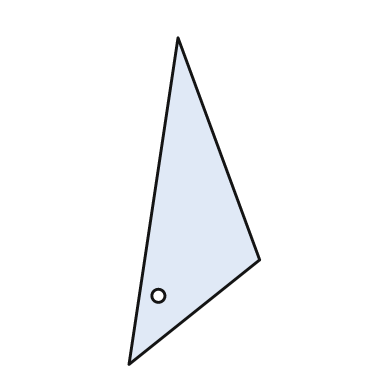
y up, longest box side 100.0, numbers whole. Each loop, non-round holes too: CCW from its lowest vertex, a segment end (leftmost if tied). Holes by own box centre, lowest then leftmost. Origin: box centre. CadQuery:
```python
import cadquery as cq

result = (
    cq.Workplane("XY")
    .moveTo(-20.0, -50.0)
    .lineTo(20.0, -18.0)
    .lineTo(-5.0, 50.0)
    .close()
    .moveTo(-11.0, -29.0)
    .circle(2.0)
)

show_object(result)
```